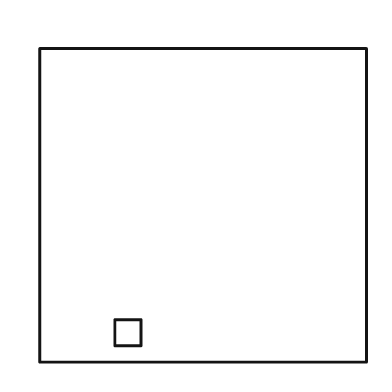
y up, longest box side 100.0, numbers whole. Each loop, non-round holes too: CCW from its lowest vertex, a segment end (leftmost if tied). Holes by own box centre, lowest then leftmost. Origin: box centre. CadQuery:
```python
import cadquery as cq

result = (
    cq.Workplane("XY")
    .moveTo(-50.0, -48.0)
    .lineTo(50.0, -48.0)
    .lineTo(50.0, 48.0)
    .lineTo(-50.0, 48.0)
    .close()
    .moveTo(-27.0, -43.0)
    .lineTo(-19.0, -43.0)
    .lineTo(-19.0, -35.0)
    .lineTo(-27.0, -35.0)
    .close()
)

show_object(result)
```